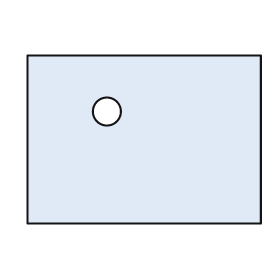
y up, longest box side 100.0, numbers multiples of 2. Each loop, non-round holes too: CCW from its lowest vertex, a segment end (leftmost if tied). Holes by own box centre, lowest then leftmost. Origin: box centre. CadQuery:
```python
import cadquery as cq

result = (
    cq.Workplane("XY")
    .moveTo(-50.0, -36.0)
    .lineTo(50.0, -36.0)
    .lineTo(50.0, 36.0)
    .lineTo(-50.0, 36.0)
    .close()
    .moveTo(-16.0, 12.0)
    .circle(6.0)
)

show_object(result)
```